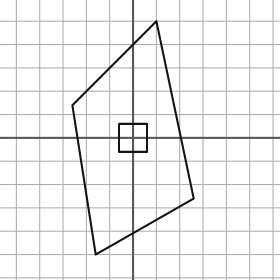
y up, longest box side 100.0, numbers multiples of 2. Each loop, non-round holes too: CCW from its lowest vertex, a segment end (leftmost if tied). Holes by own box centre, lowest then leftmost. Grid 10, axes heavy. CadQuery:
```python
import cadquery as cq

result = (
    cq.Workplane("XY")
    .moveTo(-16.0, -50.0)
    .lineTo(26.0, -26.0)
    .lineTo(10.0, 50.0)
    .lineTo(-26.0, 14.0)
    .close()
    .moveTo(-6.0, -6.0)
    .lineTo(6.0, -6.0)
    .lineTo(6.0, 6.0)
    .lineTo(-6.0, 6.0)
    .close()
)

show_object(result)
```